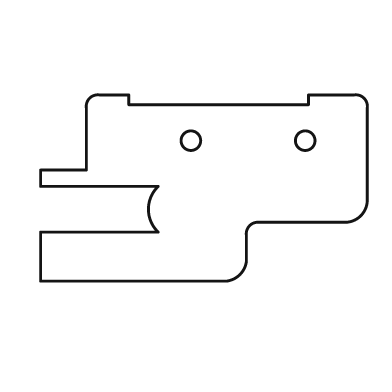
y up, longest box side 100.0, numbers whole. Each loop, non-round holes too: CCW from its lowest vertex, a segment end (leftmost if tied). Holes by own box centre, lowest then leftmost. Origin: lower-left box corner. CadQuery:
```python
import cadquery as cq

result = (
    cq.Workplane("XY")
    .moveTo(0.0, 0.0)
    .lineTo(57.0, 0.0)
    .threePointArc((61.0, 2.0), (63.0, 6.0))
    .lineTo(63.0, 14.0)
    .threePointArc((64.0, 17.0), (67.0, 18.0))
    .lineTo(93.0, 18.0)
    .threePointArc((98.0, 20.0), (100.0, 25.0))
    .lineTo(100.0, 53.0)
    .threePointArc((99.0, 56.0), (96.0, 57.0))
    .lineTo(82.0, 57.0)
    .lineTo(82.0, 54.0)
    .lineTo(27.0, 54.0)
    .lineTo(27.0, 57.0)
    .lineTo(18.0, 57.0)
    .threePointArc((15.0, 56.0), (14.0, 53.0))
    .lineTo(14.0, 34.0)
    .lineTo(0.0, 34.0)
    .lineTo(0.0, 29.0)
    .lineTo(36.0, 29.0)
    .threePointArc((33.0, 22.0), (36.0, 15.0))
    .lineTo(0.0, 15.0)
    .close()
    .moveTo(46.0, 43.0)
    .circle(3.0)
    .moveTo(81.0, 43.0)
    .circle(3.0)
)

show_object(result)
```